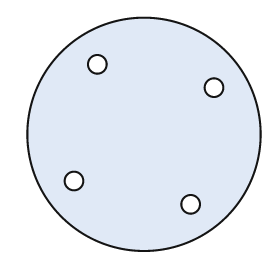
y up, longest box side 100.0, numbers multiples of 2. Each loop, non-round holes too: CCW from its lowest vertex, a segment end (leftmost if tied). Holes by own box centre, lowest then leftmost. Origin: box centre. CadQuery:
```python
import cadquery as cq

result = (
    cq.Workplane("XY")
    .moveTo(0.0, 0.0)
    .circle(50.0)
    .moveTo(20.0, -30.0)
    .circle(4.0)
    .moveTo(-30.0, -20.0)
    .circle(4.0)
    .moveTo(30.0, 20.0)
    .circle(4.0)
    .moveTo(-20.0, 30.0)
    .circle(4.0)
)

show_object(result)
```